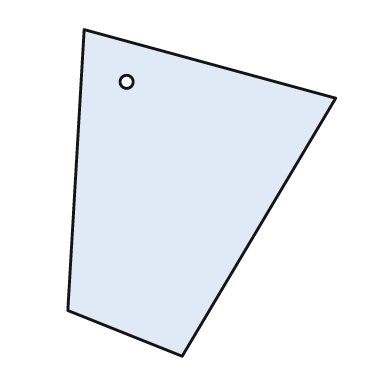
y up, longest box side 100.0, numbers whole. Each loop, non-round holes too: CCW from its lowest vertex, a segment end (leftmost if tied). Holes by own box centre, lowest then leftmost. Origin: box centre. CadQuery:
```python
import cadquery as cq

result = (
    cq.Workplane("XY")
    .moveTo(-6.0, -50.0)
    .lineTo(41.0, 29.0)
    .lineTo(-36.0, 50.0)
    .lineTo(-41.0, -36.0)
    .close()
    .moveTo(-23.0, 34.0)
    .circle(2.0)
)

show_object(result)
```